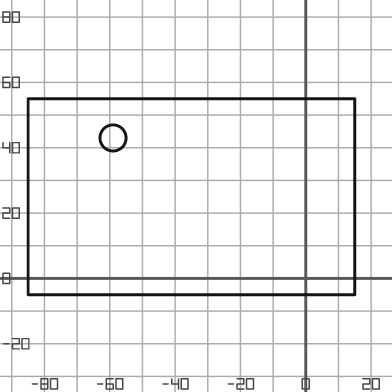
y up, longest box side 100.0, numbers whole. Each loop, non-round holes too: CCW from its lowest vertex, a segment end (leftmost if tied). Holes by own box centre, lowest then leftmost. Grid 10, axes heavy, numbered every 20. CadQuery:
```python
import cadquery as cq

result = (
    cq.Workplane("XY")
    .moveTo(-85.0, -5.0)
    .lineTo(15.0, -5.0)
    .lineTo(15.0, 55.0)
    .lineTo(-85.0, 55.0)
    .close()
    .moveTo(-59.0, 43.0)
    .circle(4.0)
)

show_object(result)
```